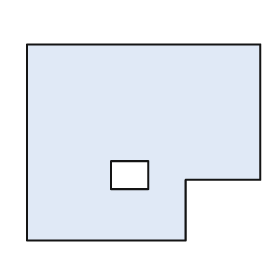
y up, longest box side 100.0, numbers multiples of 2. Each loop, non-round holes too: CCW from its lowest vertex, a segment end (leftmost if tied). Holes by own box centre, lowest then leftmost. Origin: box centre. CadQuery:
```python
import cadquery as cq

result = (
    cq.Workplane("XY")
    .moveTo(-50.0, -42.0)
    .lineTo(18.0, -42.0)
    .lineTo(18.0, -16.0)
    .lineTo(50.0, -16.0)
    .lineTo(50.0, 42.0)
    .lineTo(-50.0, 42.0)
    .close()
    .moveTo(-14.0, -20.0)
    .lineTo(2.0, -20.0)
    .lineTo(2.0, -8.0)
    .lineTo(-14.0, -8.0)
    .close()
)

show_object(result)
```